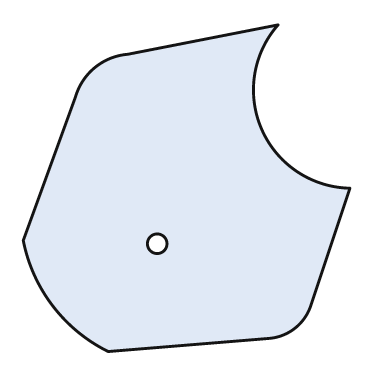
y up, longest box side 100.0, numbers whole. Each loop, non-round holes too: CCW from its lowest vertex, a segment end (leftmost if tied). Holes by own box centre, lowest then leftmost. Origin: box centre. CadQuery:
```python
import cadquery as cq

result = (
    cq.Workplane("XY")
    .moveTo(-24.0, -50.0)
    .lineTo(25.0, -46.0)
    .threePointArc((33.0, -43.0), (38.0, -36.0))
    .lineTo(50.0, 0.0)
    .threePointArc((23.0, 18.0), (28.0, 50.0))
    .lineTo(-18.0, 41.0)
    .threePointArc((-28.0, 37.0), (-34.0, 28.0))
    .lineTo(-50.0, -16.0)
    .threePointArc((-41.0, -36.0), (-24.0, -50.0))
    .close()
    .moveTo(-9.0, -17.0)
    .circle(3.0)
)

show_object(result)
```